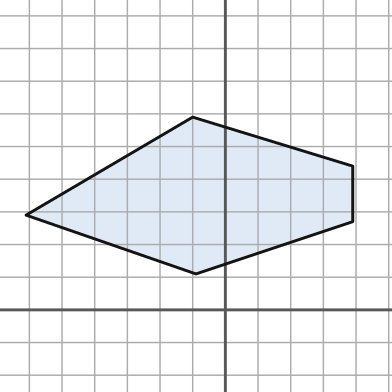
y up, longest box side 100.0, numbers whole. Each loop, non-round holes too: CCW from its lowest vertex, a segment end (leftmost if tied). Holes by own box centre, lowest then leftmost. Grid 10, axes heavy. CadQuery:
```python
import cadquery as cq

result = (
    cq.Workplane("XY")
    .moveTo(-9.0, 11.0)
    .lineTo(39.0, 27.0)
    .lineTo(39.0, 44.0)
    .lineTo(-10.0, 59.0)
    .lineTo(-61.0, 29.0)
    .close()
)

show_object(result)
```